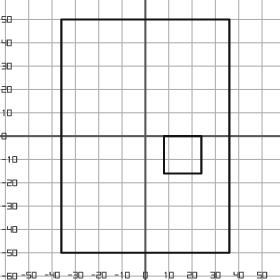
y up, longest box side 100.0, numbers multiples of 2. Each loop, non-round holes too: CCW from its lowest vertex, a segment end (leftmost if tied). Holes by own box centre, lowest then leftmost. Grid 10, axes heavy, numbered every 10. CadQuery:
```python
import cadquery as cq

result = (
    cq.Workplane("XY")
    .moveTo(-36.0, -50.0)
    .lineTo(36.0, -50.0)
    .lineTo(36.0, 50.0)
    .lineTo(-36.0, 50.0)
    .close()
    .moveTo(8.0, -16.0)
    .lineTo(24.0, -16.0)
    .lineTo(24.0, 0.0)
    .lineTo(8.0, 0.0)
    .close()
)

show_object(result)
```